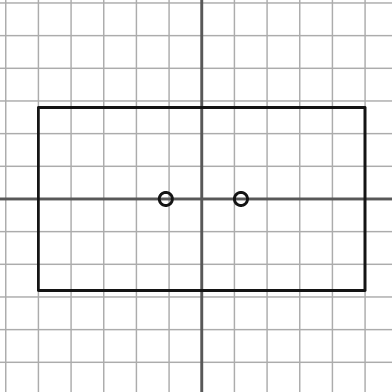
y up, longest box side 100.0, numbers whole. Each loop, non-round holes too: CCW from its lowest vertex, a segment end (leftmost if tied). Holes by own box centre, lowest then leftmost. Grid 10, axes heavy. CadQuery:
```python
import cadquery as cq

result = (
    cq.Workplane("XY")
    .moveTo(-50.0, -28.0)
    .lineTo(50.0, -28.0)
    .lineTo(50.0, 28.0)
    .lineTo(-50.0, 28.0)
    .close()
    .moveTo(-11.0, 0.0)
    .circle(2.0)
    .moveTo(12.0, 0.0)
    .circle(2.0)
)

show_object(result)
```